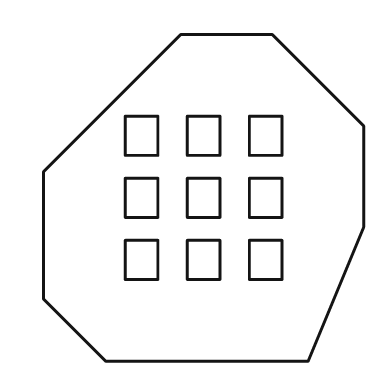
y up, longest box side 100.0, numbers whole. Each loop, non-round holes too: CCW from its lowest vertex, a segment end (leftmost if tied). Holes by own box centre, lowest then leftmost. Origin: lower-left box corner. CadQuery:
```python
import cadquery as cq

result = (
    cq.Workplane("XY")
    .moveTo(19.0, 0.0)
    .lineTo(81.0, 0.0)
    .lineTo(98.0, 41.0)
    .lineTo(98.0, 72.0)
    .lineTo(70.0, 100.0)
    .lineTo(42.0, 100.0)
    .lineTo(0.0, 58.0)
    .lineTo(0.0, 19.0)
    .close()
    .moveTo(25.0, 25.0)
    .lineTo(35.0, 25.0)
    .lineTo(35.0, 37.0)
    .lineTo(25.0, 37.0)
    .close()
    .moveTo(44.0, 25.0)
    .lineTo(54.0, 25.0)
    .lineTo(54.0, 37.0)
    .lineTo(44.0, 37.0)
    .close()
    .moveTo(63.0, 25.0)
    .lineTo(73.0, 25.0)
    .lineTo(73.0, 37.0)
    .lineTo(63.0, 37.0)
    .close()
    .moveTo(25.0, 44.0)
    .lineTo(35.0, 44.0)
    .lineTo(35.0, 56.0)
    .lineTo(25.0, 56.0)
    .close()
    .moveTo(44.0, 44.0)
    .lineTo(54.0, 44.0)
    .lineTo(54.0, 56.0)
    .lineTo(44.0, 56.0)
    .close()
    .moveTo(63.0, 44.0)
    .lineTo(73.0, 44.0)
    .lineTo(73.0, 56.0)
    .lineTo(63.0, 56.0)
    .close()
    .moveTo(25.0, 63.0)
    .lineTo(35.0, 63.0)
    .lineTo(35.0, 75.0)
    .lineTo(25.0, 75.0)
    .close()
    .moveTo(44.0, 63.0)
    .lineTo(54.0, 63.0)
    .lineTo(54.0, 75.0)
    .lineTo(44.0, 75.0)
    .close()
    .moveTo(63.0, 63.0)
    .lineTo(73.0, 63.0)
    .lineTo(73.0, 75.0)
    .lineTo(63.0, 75.0)
    .close()
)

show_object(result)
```